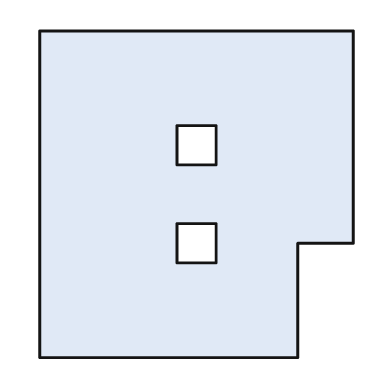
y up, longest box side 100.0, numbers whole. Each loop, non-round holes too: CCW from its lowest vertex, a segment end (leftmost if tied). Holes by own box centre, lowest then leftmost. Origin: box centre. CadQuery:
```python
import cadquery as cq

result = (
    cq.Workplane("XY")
    .moveTo(-48.0, -50.0)
    .lineTo(31.0, -50.0)
    .lineTo(31.0, -15.0)
    .lineTo(48.0, -15.0)
    .lineTo(48.0, 50.0)
    .lineTo(-48.0, 50.0)
    .close()
    .moveTo(-6.0, -21.0)
    .lineTo(6.0, -21.0)
    .lineTo(6.0, -9.0)
    .lineTo(-6.0, -9.0)
    .close()
    .moveTo(-6.0, 9.0)
    .lineTo(6.0, 9.0)
    .lineTo(6.0, 21.0)
    .lineTo(-6.0, 21.0)
    .close()
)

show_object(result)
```